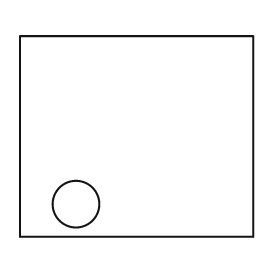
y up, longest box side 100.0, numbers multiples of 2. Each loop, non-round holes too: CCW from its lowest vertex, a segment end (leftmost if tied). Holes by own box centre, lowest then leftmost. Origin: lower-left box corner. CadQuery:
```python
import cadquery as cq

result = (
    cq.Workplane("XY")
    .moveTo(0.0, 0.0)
    .lineTo(100.0, 0.0)
    .lineTo(100.0, 86.0)
    .lineTo(0.0, 86.0)
    .close()
    .moveTo(24.0, 14.0)
    .circle(10.0)
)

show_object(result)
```